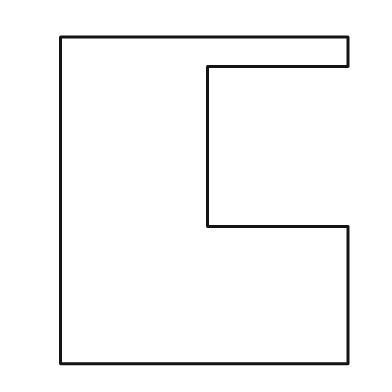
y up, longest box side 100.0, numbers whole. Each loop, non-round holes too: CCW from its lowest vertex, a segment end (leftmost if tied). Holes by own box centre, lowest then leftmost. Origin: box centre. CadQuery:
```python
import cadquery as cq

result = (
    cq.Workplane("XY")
    .moveTo(-44.0, -50.0)
    .lineTo(44.0, -50.0)
    .lineTo(44.0, -8.0)
    .lineTo(1.0, -8.0)
    .lineTo(1.0, 41.0)
    .lineTo(44.0, 41.0)
    .lineTo(44.0, 50.0)
    .lineTo(-44.0, 50.0)
    .close()
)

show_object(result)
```